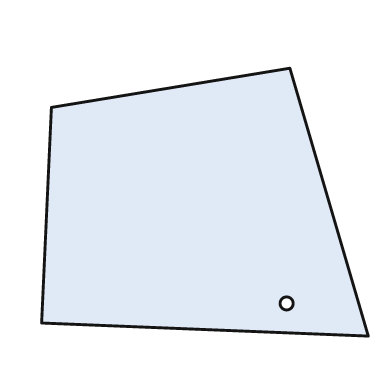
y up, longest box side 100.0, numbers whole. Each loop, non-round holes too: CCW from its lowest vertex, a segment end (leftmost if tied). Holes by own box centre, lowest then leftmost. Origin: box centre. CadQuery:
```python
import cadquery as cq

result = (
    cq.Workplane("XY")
    .moveTo(50.0, -41.0)
    .lineTo(26.0, 41.0)
    .lineTo(-47.0, 29.0)
    .lineTo(-50.0, -37.0)
    .close()
    .moveTo(25.0, -31.0)
    .circle(2.0)
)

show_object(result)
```